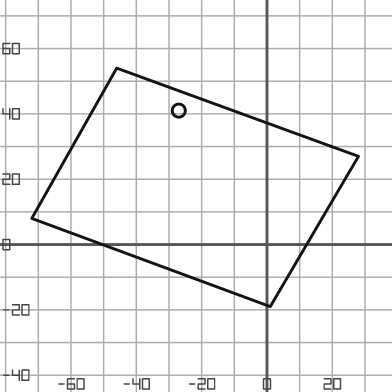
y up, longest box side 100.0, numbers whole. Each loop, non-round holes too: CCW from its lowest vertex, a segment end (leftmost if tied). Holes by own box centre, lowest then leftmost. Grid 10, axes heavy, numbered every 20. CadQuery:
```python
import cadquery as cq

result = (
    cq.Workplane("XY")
    .moveTo(1.0, -19.0)
    .lineTo(28.0, 27.0)
    .lineTo(-46.0, 54.0)
    .lineTo(-72.0, 8.0)
    .close()
    .moveTo(-27.0, 41.0)
    .circle(2.0)
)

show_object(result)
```